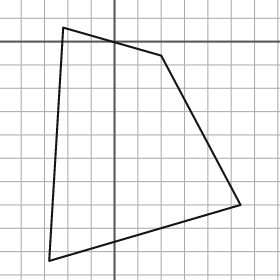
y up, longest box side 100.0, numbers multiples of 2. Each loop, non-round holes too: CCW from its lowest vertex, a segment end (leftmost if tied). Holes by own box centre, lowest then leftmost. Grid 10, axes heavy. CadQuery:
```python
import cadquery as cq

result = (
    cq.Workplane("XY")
    .moveTo(-28.0, -94.0)
    .lineTo(54.0, -70.0)
    .lineTo(20.0, -6.0)
    .lineTo(-22.0, 6.0)
    .close()
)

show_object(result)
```